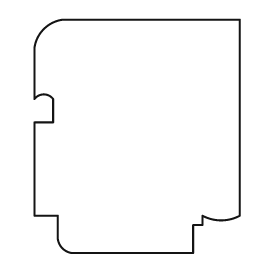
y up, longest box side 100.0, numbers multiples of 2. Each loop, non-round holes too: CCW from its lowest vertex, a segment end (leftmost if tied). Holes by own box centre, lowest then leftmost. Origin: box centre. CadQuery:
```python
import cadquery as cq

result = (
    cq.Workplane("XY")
    .moveTo(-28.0, -50.0)
    .lineTo(24.0, -50.0)
    .lineTo(24.0, -38.0)
    .lineTo(28.0, -38.0)
    .lineTo(28.0, -34.0)
    .threePointArc((36.0, -36.0), (44.0, -34.0))
    .lineTo(44.0, 50.0)
    .lineTo(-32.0, 50.0)
    .threePointArc((-40.0, 46.0), (-44.0, 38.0))
    .lineTo(-44.0, 16.0)
    .threePointArc((-40.0, 18.0), (-36.0, 16.0))
    .lineTo(-36.0, 6.0)
    .lineTo(-44.0, 6.0)
    .lineTo(-44.0, -34.0)
    .lineTo(-34.0, -34.0)
    .lineTo(-34.0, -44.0)
    .threePointArc((-32.0, -48.0), (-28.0, -50.0))
    .close()
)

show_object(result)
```